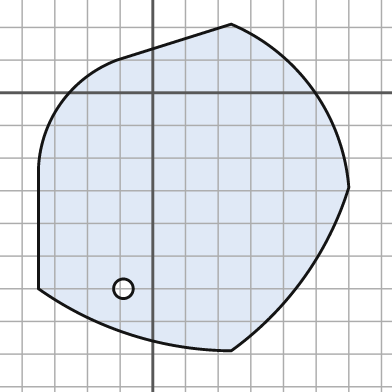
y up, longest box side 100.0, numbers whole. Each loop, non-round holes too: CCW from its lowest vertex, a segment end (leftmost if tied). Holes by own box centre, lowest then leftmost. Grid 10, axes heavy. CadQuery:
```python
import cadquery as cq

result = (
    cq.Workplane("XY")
    .moveTo(24.0, -79.0)
    .threePointArc((46.0, -57.0), (60.0, -29.0))
    .threePointArc((49.0, 1.0), (24.0, 21.0))
    .lineTo(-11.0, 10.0)
    .threePointArc((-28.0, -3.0), (-35.0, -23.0))
    .lineTo(-35.0, -60.0)
    .threePointArc((-7.0, -74.0), (24.0, -79.0))
    .close()
    .moveTo(-9.0, -60.0)
    .circle(3.0)
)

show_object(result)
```